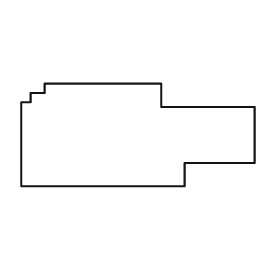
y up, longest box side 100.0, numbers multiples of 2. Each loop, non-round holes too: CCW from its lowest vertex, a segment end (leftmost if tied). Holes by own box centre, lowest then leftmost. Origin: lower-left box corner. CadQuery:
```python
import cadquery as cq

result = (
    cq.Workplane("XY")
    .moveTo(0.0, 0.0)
    .lineTo(70.0, 0.0)
    .lineTo(70.0, 10.0)
    .lineTo(100.0, 10.0)
    .lineTo(100.0, 34.0)
    .lineTo(60.0, 34.0)
    .lineTo(60.0, 44.0)
    .lineTo(10.0, 44.0)
    .lineTo(10.0, 40.0)
    .lineTo(4.0, 40.0)
    .lineTo(4.0, 36.0)
    .lineTo(0.0, 36.0)
    .close()
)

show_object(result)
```